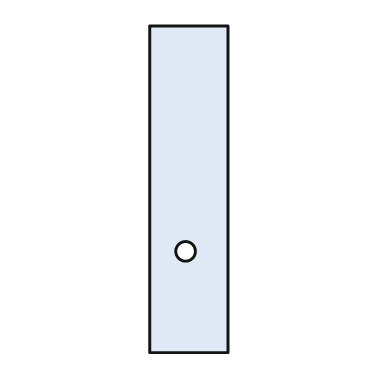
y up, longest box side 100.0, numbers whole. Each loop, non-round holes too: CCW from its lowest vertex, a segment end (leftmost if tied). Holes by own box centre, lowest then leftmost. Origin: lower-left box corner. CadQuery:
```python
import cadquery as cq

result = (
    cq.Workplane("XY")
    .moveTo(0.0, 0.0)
    .lineTo(24.0, 0.0)
    .lineTo(24.0, 100.0)
    .lineTo(0.0, 100.0)
    .close()
    .moveTo(11.0, 31.0)
    .circle(3.0)
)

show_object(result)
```